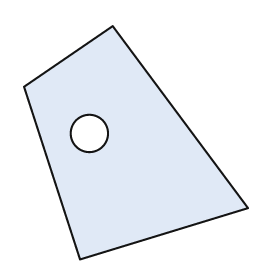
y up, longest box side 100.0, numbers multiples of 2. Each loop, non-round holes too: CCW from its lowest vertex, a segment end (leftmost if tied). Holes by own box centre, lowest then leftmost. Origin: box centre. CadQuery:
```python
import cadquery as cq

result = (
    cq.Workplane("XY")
    .moveTo(-24.0, -50.0)
    .lineTo(48.0, -28.0)
    .lineTo(-10.0, 50.0)
    .lineTo(-48.0, 24.0)
    .close()
    .moveTo(-20.0, 4.0)
    .circle(8.0)
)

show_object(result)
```